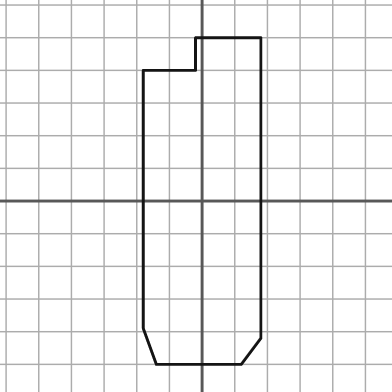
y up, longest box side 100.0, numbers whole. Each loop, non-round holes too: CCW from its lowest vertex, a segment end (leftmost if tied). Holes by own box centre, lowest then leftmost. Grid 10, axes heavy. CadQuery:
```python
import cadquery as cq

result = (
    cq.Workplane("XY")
    .moveTo(-14.0, -50.0)
    .lineTo(12.0, -50.0)
    .lineTo(18.0, -42.0)
    .lineTo(18.0, 50.0)
    .lineTo(-2.0, 50.0)
    .lineTo(-2.0, 40.0)
    .lineTo(-18.0, 40.0)
    .lineTo(-18.0, -39.0)
    .close()
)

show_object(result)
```